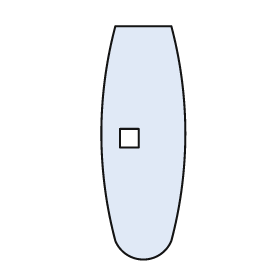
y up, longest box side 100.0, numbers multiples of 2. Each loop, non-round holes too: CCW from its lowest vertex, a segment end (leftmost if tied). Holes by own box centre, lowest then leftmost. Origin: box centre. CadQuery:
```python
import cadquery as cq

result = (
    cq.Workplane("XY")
    .moveTo(-12.0, -42.0)
    .threePointArc((0.0, -50.0), (12.0, -42.0))
    .threePointArc((18.0, 4.0), (12.0, 50.0))
    .lineTo(-12.0, 50.0)
    .threePointArc((-18.0, 4.0), (-12.0, -42.0))
    .close()
    .moveTo(-10.0, -2.0)
    .lineTo(-2.0, -2.0)
    .lineTo(-2.0, 6.0)
    .lineTo(-10.0, 6.0)
    .close()
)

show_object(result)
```